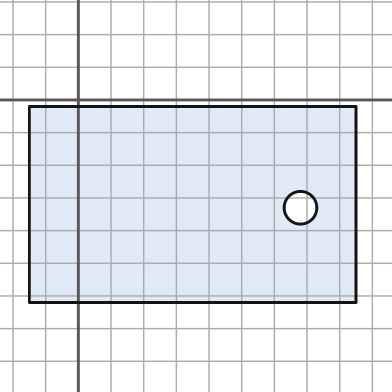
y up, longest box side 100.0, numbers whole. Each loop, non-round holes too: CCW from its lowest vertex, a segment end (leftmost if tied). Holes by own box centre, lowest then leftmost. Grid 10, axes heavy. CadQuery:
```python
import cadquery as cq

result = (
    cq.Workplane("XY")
    .moveTo(-15.0, -62.0)
    .lineTo(85.0, -62.0)
    .lineTo(85.0, -2.0)
    .lineTo(-15.0, -2.0)
    .close()
    .moveTo(68.0, -33.0)
    .circle(5.0)
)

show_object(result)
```